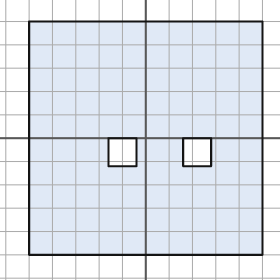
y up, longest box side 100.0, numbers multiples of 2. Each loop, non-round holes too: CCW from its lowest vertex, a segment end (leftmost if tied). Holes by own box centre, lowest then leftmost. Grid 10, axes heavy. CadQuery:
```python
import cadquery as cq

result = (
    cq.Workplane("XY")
    .moveTo(-50.0, -50.0)
    .lineTo(50.0, -50.0)
    .lineTo(50.0, 50.0)
    .lineTo(-50.0, 50.0)
    .close()
    .moveTo(-16.0, -12.0)
    .lineTo(-4.0, -12.0)
    .lineTo(-4.0, 0.0)
    .lineTo(-16.0, 0.0)
    .close()
    .moveTo(16.0, -12.0)
    .lineTo(28.0, -12.0)
    .lineTo(28.0, 0.0)
    .lineTo(16.0, 0.0)
    .close()
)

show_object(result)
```